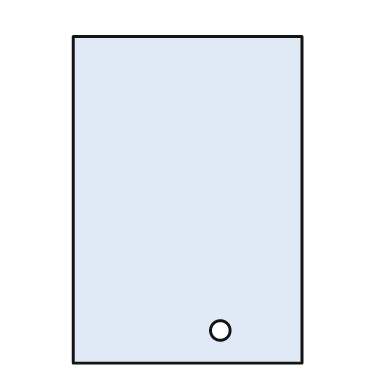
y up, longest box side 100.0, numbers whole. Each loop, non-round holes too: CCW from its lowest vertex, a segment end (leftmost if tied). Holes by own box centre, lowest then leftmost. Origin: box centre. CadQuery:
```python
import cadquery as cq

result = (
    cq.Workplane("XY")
    .moveTo(-35.0, -50.0)
    .lineTo(35.0, -50.0)
    .lineTo(35.0, 50.0)
    .lineTo(-35.0, 50.0)
    .close()
    .moveTo(10.0, -40.0)
    .circle(3.0)
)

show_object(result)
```